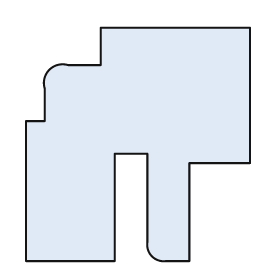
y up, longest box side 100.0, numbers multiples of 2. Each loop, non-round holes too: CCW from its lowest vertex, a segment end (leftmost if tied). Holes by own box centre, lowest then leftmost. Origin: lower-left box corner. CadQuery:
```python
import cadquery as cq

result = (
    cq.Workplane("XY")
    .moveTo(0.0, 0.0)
    .lineTo(38.0, 0.0)
    .lineTo(38.0, 46.0)
    .lineTo(52.0, 46.0)
    .lineTo(52.0, 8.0)
    .threePointArc((54.0, 2.0), (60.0, 0.0))
    .lineTo(70.0, 0.0)
    .lineTo(70.0, 42.0)
    .lineTo(96.0, 42.0)
    .lineTo(96.0, 100.0)
    .lineTo(32.0, 100.0)
    .lineTo(32.0, 84.0)
    .lineTo(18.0, 84.0)
    .threePointArc((10.0, 82.0), (8.0, 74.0))
    .lineTo(8.0, 60.0)
    .lineTo(0.0, 60.0)
    .close()
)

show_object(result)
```